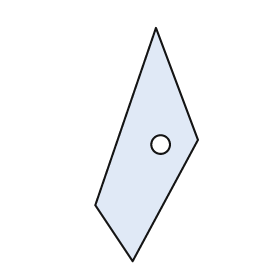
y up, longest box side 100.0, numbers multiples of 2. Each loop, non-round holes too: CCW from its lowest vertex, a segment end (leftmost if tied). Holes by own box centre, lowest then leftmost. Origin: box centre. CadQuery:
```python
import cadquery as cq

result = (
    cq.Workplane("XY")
    .moveTo(-6.0, -50.0)
    .lineTo(22.0, 2.0)
    .lineTo(4.0, 50.0)
    .lineTo(-22.0, -26.0)
    .close()
    .moveTo(6.0, 0.0)
    .circle(4.0)
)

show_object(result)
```